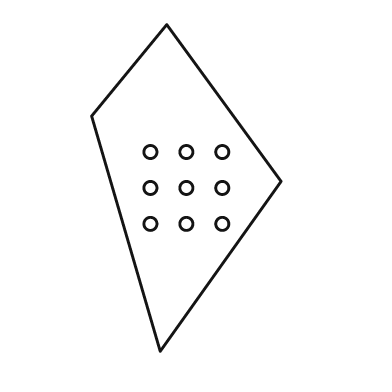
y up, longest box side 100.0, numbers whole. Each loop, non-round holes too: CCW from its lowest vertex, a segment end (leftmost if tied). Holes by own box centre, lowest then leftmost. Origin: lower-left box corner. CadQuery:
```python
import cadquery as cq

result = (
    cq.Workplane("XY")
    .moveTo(21.0, 0.0)
    .lineTo(58.0, 52.0)
    .lineTo(23.0, 100.0)
    .lineTo(0.0, 72.0)
    .close()
    .moveTo(18.0, 39.0)
    .circle(2.0)
    .moveTo(29.0, 39.0)
    .circle(2.0)
    .moveTo(40.0, 39.0)
    .circle(2.0)
    .moveTo(18.0, 50.0)
    .circle(2.0)
    .moveTo(29.0, 50.0)
    .circle(2.0)
    .moveTo(40.0, 50.0)
    .circle(2.0)
    .moveTo(18.0, 61.0)
    .circle(2.0)
    .moveTo(29.0, 61.0)
    .circle(2.0)
    .moveTo(40.0, 61.0)
    .circle(2.0)
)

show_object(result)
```